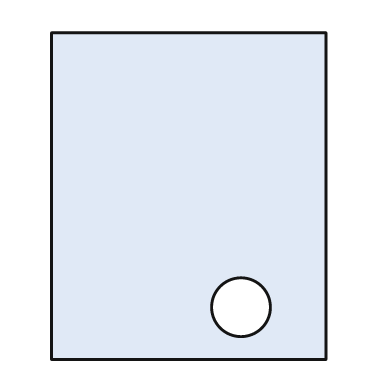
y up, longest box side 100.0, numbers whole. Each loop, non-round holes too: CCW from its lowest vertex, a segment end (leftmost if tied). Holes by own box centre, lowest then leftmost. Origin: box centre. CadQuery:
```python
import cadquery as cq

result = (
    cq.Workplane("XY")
    .moveTo(-42.0, -50.0)
    .lineTo(42.0, -50.0)
    .lineTo(42.0, 50.0)
    .lineTo(-42.0, 50.0)
    .close()
    .moveTo(16.0, -34.0)
    .circle(9.0)
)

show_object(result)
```